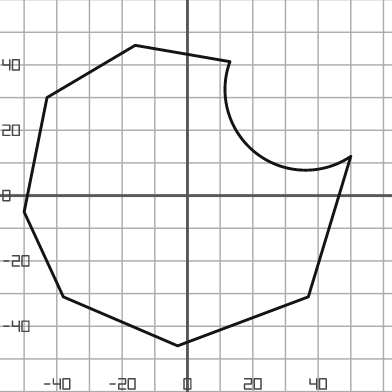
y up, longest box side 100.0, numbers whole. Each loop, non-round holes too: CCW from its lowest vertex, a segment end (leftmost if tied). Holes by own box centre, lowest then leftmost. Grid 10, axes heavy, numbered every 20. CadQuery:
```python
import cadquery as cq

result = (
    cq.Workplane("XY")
    .moveTo(-3.0, -46.0)
    .lineTo(37.0, -31.0)
    .lineTo(50.0, 12.0)
    .threePointArc((21.0, 13.0), (13.0, 41.0))
    .lineTo(-16.0, 46.0)
    .lineTo(-43.0, 30.0)
    .lineTo(-50.0, -5.0)
    .lineTo(-38.0, -31.0)
    .close()
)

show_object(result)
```